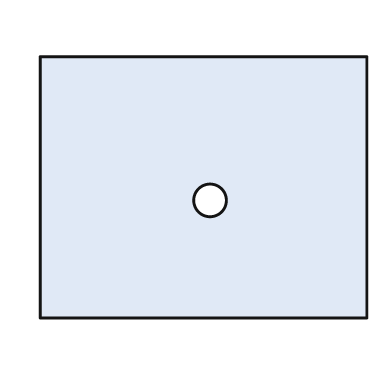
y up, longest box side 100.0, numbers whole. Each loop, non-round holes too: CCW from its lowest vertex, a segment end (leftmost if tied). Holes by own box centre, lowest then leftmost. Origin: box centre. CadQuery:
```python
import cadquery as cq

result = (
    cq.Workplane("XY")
    .moveTo(-50.0, -40.0)
    .lineTo(50.0, -40.0)
    .lineTo(50.0, 40.0)
    .lineTo(-50.0, 40.0)
    .close()
    .moveTo(2.0, -4.0)
    .circle(5.0)
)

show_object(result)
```